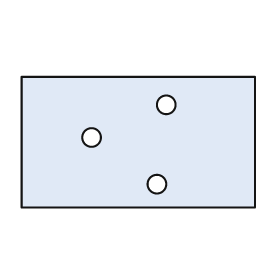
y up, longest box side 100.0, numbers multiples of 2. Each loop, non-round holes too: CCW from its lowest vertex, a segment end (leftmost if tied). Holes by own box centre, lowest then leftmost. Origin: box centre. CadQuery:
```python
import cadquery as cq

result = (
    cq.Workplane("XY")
    .moveTo(-50.0, -28.0)
    .lineTo(50.0, -28.0)
    .lineTo(50.0, 28.0)
    .lineTo(-50.0, 28.0)
    .close()
    .moveTo(8.0, -18.0)
    .circle(4.0)
    .moveTo(-20.0, 2.0)
    .circle(4.0)
    .moveTo(12.0, 16.0)
    .circle(4.0)
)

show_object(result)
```